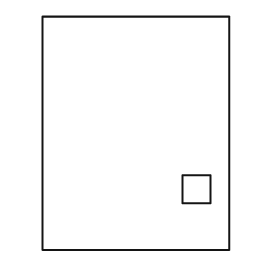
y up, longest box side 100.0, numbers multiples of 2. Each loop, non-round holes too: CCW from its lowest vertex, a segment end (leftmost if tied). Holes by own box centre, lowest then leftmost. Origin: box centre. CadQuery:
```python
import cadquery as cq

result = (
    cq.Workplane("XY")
    .moveTo(-40.0, -50.0)
    .lineTo(40.0, -50.0)
    .lineTo(40.0, 50.0)
    .lineTo(-40.0, 50.0)
    .close()
    .moveTo(20.0, -30.0)
    .lineTo(32.0, -30.0)
    .lineTo(32.0, -18.0)
    .lineTo(20.0, -18.0)
    .close()
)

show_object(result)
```